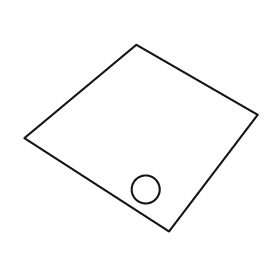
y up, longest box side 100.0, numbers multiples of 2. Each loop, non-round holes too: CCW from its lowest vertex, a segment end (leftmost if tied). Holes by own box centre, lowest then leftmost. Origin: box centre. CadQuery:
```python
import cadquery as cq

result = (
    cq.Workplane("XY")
    .moveTo(12.0, -40.0)
    .lineTo(50.0, 10.0)
    .lineTo(-2.0, 40.0)
    .lineTo(-50.0, 0.0)
    .close()
    .moveTo(2.0, -22.0)
    .circle(6.0)
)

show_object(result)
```